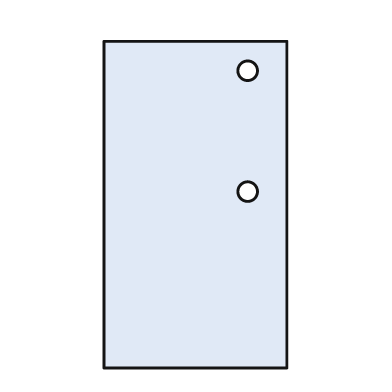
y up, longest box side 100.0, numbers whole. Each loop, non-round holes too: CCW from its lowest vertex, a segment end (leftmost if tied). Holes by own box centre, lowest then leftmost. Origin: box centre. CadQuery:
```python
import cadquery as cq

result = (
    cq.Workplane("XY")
    .moveTo(-28.0, -50.0)
    .lineTo(28.0, -50.0)
    .lineTo(28.0, 50.0)
    .lineTo(-28.0, 50.0)
    .close()
    .moveTo(16.0, 4.0)
    .circle(3.0)
    .moveTo(16.0, 41.0)
    .circle(3.0)
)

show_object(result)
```